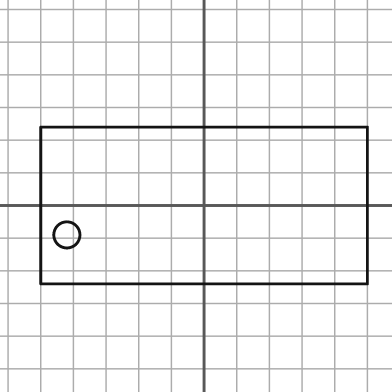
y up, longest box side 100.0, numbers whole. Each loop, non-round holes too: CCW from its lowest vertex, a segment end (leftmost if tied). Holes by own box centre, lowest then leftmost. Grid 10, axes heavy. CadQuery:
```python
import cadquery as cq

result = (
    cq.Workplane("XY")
    .moveTo(-50.0, -24.0)
    .lineTo(50.0, -24.0)
    .lineTo(50.0, 24.0)
    .lineTo(-50.0, 24.0)
    .close()
    .moveTo(-42.0, -9.0)
    .circle(4.0)
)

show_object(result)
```